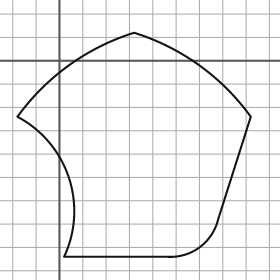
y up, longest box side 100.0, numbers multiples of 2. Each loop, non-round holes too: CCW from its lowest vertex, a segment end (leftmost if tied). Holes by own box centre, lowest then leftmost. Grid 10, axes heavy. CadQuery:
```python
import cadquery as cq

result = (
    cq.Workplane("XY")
    .moveTo(2.0, -84.0)
    .lineTo(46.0, -84.0)
    .threePointArc((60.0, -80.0), (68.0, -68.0))
    .lineTo(82.0, -24.0)
    .threePointArc((60.0, -2.0), (32.0, 12.0))
    .threePointArc((4.0, -2.0), (-18.0, -24.0))
    .threePointArc((4.0, -50.0), (2.0, -84.0))
    .close()
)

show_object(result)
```